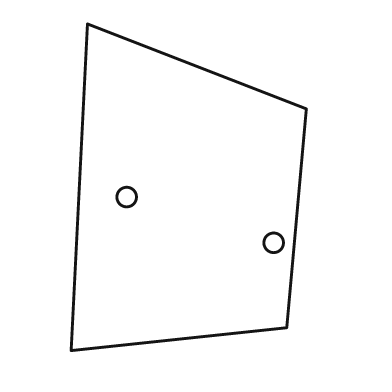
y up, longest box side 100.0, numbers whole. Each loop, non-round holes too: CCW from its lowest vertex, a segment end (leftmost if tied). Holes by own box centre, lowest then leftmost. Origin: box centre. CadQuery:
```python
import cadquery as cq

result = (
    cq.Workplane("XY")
    .moveTo(-36.0, -50.0)
    .lineTo(30.0, -43.0)
    .lineTo(36.0, 24.0)
    .lineTo(-31.0, 50.0)
    .close()
    .moveTo(26.0, -17.0)
    .circle(3.0)
    .moveTo(-19.0, -3.0)
    .circle(3.0)
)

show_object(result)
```